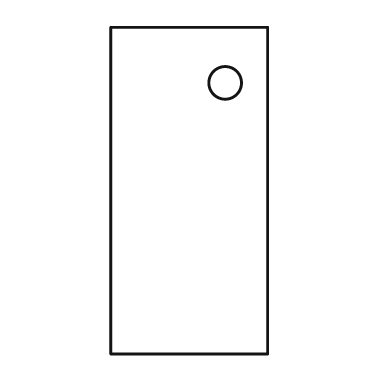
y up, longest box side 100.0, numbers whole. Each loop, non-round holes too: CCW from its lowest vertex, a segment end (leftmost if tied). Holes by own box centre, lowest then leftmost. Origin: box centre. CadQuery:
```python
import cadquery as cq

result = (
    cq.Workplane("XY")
    .moveTo(-24.0, -50.0)
    .lineTo(24.0, -50.0)
    .lineTo(24.0, 50.0)
    .lineTo(-24.0, 50.0)
    .close()
    .moveTo(11.0, 33.0)
    .circle(5.0)
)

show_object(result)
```